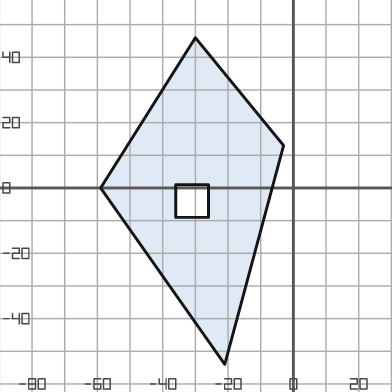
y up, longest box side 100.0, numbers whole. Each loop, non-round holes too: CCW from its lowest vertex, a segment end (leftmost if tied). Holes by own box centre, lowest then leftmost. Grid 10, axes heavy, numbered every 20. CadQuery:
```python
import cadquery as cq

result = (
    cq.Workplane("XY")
    .moveTo(-21.0, -54.0)
    .lineTo(-3.0, 13.0)
    .lineTo(-30.0, 46.0)
    .lineTo(-59.0, 0.0)
    .close()
    .moveTo(-36.0, -9.0)
    .lineTo(-26.0, -9.0)
    .lineTo(-26.0, 1.0)
    .lineTo(-36.0, 1.0)
    .close()
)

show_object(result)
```